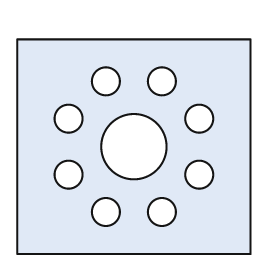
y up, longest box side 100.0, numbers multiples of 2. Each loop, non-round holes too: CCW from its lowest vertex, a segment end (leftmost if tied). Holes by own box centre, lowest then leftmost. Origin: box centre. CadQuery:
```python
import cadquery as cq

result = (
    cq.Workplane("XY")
    .moveTo(-50.0, -46.0)
    .lineTo(50.0, -46.0)
    .lineTo(50.0, 46.0)
    .lineTo(-50.0, 46.0)
    .close()
    .moveTo(-12.0, -28.0)
    .circle(6.0)
    .moveTo(12.0, -28.0)
    .circle(6.0)
    .moveTo(-28.0, -12.0)
    .circle(6.0)
    .moveTo(28.0, -12.0)
    .circle(6.0)
    .moveTo(0.0, 0.0)
    .circle(14.0)
    .moveTo(-28.0, 12.0)
    .circle(6.0)
    .moveTo(28.0, 12.0)
    .circle(6.0)
    .moveTo(-12.0, 28.0)
    .circle(6.0)
    .moveTo(12.0, 28.0)
    .circle(6.0)
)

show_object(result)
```